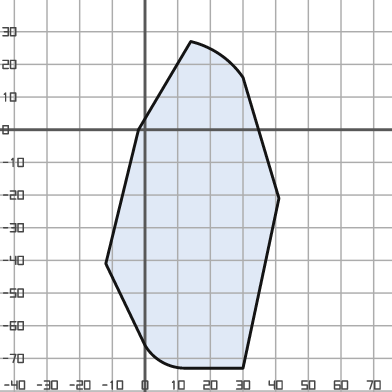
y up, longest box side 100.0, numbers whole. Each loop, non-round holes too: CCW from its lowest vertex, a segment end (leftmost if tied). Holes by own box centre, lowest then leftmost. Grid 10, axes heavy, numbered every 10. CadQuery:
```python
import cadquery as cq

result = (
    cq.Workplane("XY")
    .moveTo(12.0, -73.0)
    .lineTo(30.0, -73.0)
    .lineTo(41.0, -21.0)
    .lineTo(30.0, 16.0)
    .threePointArc((23.0, 23.0), (14.0, 27.0))
    .lineTo(-2.0, 0.0)
    .lineTo(-12.0, -41.0)
    .lineTo(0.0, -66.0)
    .threePointArc((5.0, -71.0), (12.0, -73.0))
    .close()
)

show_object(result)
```